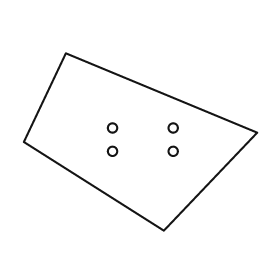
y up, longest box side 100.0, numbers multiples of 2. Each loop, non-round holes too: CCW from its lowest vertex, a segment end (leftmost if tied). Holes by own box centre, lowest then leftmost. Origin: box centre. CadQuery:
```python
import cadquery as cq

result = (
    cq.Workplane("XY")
    .moveTo(10.0, -38.0)
    .lineTo(50.0, 4.0)
    .lineTo(-32.0, 38.0)
    .lineTo(-50.0, 0.0)
    .close()
    .moveTo(-12.0, -4.0)
    .circle(2.0)
    .moveTo(14.0, -4.0)
    .circle(2.0)
    .moveTo(-12.0, 6.0)
    .circle(2.0)
    .moveTo(14.0, 6.0)
    .circle(2.0)
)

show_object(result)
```